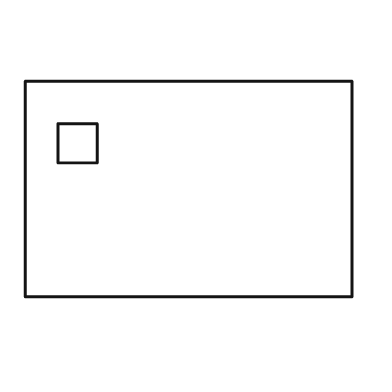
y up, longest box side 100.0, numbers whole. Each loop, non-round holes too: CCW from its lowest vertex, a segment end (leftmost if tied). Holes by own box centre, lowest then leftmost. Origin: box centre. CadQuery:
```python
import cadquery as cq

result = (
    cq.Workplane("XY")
    .moveTo(-50.0, -33.0)
    .lineTo(50.0, -33.0)
    .lineTo(50.0, 33.0)
    .lineTo(-50.0, 33.0)
    .close()
    .moveTo(-40.0, 8.0)
    .lineTo(-28.0, 8.0)
    .lineTo(-28.0, 20.0)
    .lineTo(-40.0, 20.0)
    .close()
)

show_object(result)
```